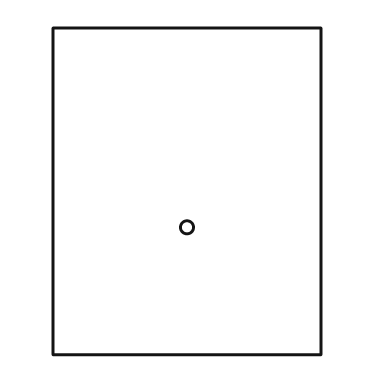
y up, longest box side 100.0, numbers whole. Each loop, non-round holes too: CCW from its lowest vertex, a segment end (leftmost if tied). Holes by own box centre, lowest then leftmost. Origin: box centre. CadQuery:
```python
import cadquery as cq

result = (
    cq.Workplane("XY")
    .moveTo(-41.0, -50.0)
    .lineTo(41.0, -50.0)
    .lineTo(41.0, 50.0)
    .lineTo(-41.0, 50.0)
    .close()
    .moveTo(0.0, -11.0)
    .circle(2.0)
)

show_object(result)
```